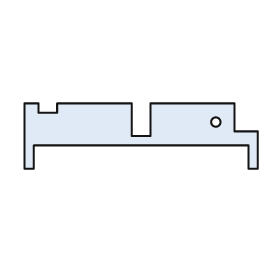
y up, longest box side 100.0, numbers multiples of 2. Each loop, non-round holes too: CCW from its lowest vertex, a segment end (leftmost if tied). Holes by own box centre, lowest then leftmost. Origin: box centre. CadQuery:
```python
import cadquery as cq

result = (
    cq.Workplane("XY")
    .moveTo(-50.0, -14.0)
    .lineTo(-46.0, -14.0)
    .lineTo(-46.0, -4.0)
    .lineTo(46.0, -4.0)
    .lineTo(46.0, -14.0)
    .lineTo(50.0, -14.0)
    .lineTo(50.0, 2.0)
    .lineTo(40.0, 2.0)
    .lineTo(40.0, 14.0)
    .lineTo(4.0, 14.0)
    .lineTo(4.0, 0.0)
    .lineTo(-4.0, 0.0)
    .lineTo(-4.0, 14.0)
    .lineTo(-36.0, 14.0)
    .lineTo(-36.0, 10.0)
    .lineTo(-44.0, 10.0)
    .lineTo(-44.0, 14.0)
    .lineTo(-50.0, 14.0)
    .close()
    .moveTo(32.0, 6.0)
    .circle(2.0)
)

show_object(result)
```